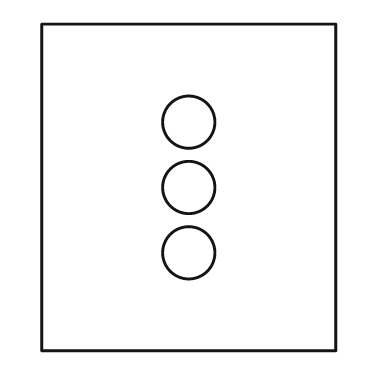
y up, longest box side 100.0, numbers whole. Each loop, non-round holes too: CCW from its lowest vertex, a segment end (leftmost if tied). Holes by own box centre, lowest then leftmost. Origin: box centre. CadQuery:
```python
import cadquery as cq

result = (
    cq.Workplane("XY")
    .moveTo(-45.0, -50.0)
    .lineTo(45.0, -50.0)
    .lineTo(45.0, 50.0)
    .lineTo(-45.0, 50.0)
    .close()
    .moveTo(0.0, -20.0)
    .circle(8.0)
    .moveTo(0.0, 0.0)
    .circle(8.0)
    .moveTo(0.0, 20.0)
    .circle(8.0)
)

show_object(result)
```